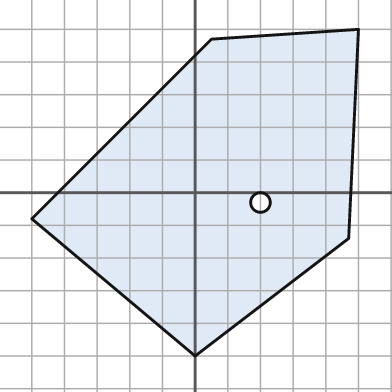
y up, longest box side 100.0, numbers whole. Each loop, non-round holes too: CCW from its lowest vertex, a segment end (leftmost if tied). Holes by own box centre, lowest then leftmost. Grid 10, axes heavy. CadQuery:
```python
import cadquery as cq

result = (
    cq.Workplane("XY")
    .moveTo(0.0, -50.0)
    .lineTo(47.0, -14.0)
    .lineTo(50.0, 50.0)
    .lineTo(5.0, 47.0)
    .lineTo(-50.0, -8.0)
    .close()
    .moveTo(20.0, -3.0)
    .circle(3.0)
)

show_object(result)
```